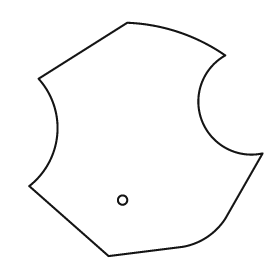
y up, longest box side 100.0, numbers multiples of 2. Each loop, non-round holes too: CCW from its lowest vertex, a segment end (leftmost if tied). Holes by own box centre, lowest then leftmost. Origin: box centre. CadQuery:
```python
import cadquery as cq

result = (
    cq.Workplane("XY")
    .moveTo(-16.0, -50.0)
    .lineTo(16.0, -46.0)
    .threePointArc((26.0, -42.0), (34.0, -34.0))
    .lineTo(50.0, -6.0)
    .threePointArc((24.0, 8.0), (34.0, 36.0))
    .threePointArc((14.0, 46.0), (-8.0, 50.0))
    .lineTo(-46.0, 26.0)
    .threePointArc((-38.0, 2.0), (-50.0, -20.0))
    .close()
    .moveTo(-10.0, -26.0)
    .circle(2.0)
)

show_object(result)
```